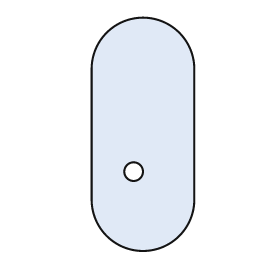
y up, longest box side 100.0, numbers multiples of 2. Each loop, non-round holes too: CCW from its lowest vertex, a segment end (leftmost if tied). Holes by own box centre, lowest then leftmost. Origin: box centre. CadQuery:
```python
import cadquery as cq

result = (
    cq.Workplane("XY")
    .moveTo(-22.0, -28.0)
    .threePointArc((0.0, -50.0), (22.0, -28.0))
    .lineTo(22.0, 28.0)
    .threePointArc((0.0, 50.0), (-22.0, 28.0))
    .close()
    .moveTo(-4.0, -16.0)
    .circle(4.0)
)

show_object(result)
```